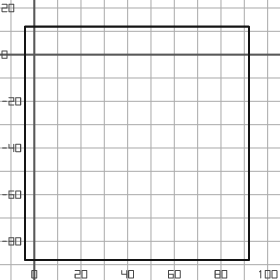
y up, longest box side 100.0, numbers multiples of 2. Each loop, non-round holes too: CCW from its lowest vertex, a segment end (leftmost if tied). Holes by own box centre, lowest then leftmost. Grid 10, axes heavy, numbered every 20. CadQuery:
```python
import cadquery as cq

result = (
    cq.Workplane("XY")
    .moveTo(-4.0, -88.0)
    .lineTo(92.0, -88.0)
    .lineTo(92.0, 12.0)
    .lineTo(-4.0, 12.0)
    .close()
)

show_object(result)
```